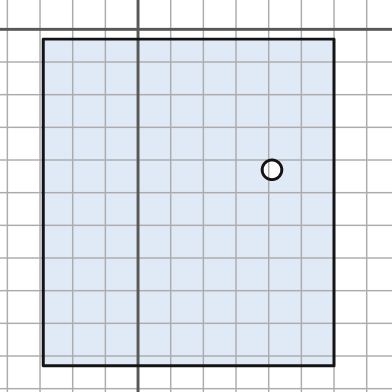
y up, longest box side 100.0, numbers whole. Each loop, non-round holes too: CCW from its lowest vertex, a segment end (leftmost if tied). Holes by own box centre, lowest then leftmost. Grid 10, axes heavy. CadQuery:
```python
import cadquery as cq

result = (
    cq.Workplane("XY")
    .moveTo(-29.0, -103.0)
    .lineTo(60.0, -103.0)
    .lineTo(60.0, -3.0)
    .lineTo(-29.0, -3.0)
    .close()
    .moveTo(41.0, -43.0)
    .circle(3.0)
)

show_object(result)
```